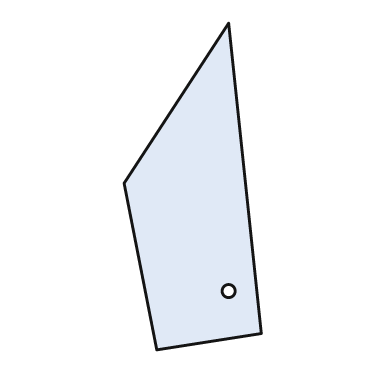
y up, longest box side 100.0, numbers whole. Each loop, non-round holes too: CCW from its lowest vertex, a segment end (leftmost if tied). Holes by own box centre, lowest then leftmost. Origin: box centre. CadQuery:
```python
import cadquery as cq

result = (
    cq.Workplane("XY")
    .moveTo(-11.0, -50.0)
    .lineTo(21.0, -45.0)
    .lineTo(11.0, 50.0)
    .lineTo(-21.0, 1.0)
    .close()
    .moveTo(11.0, -32.0)
    .circle(2.0)
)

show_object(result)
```